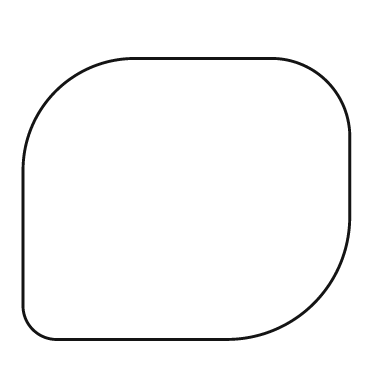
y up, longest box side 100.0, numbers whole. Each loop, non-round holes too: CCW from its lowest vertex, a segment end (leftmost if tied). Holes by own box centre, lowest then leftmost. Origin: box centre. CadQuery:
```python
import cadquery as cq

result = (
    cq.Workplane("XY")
    .moveTo(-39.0, -43.0)
    .lineTo(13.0, -43.0)
    .threePointArc((39.0, -32.0), (50.0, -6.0))
    .lineTo(50.0, 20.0)
    .threePointArc((43.0, 36.0), (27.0, 43.0))
    .lineTo(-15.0, 43.0)
    .threePointArc((-40.0, 33.0), (-50.0, 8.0))
    .lineTo(-50.0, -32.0)
    .threePointArc((-47.0, -40.0), (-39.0, -43.0))
    .close()
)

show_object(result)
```